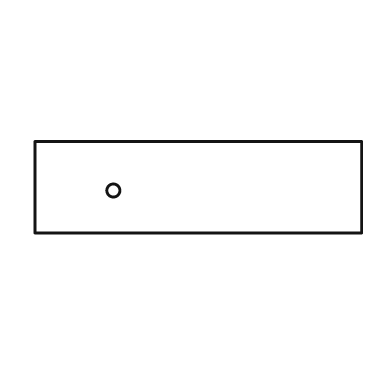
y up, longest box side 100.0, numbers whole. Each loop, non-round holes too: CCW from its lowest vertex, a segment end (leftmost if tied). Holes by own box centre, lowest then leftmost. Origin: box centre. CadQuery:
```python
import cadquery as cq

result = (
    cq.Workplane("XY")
    .moveTo(-50.0, -14.0)
    .lineTo(50.0, -14.0)
    .lineTo(50.0, 14.0)
    .lineTo(-50.0, 14.0)
    .close()
    .moveTo(-26.0, -1.0)
    .circle(2.0)
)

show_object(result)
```